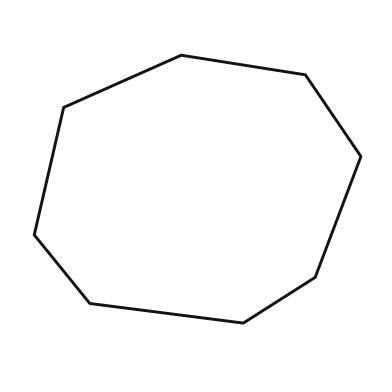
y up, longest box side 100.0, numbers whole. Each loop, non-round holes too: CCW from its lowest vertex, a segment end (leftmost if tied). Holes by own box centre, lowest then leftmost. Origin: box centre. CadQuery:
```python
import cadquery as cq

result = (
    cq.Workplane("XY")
    .moveTo(14.0, -41.0)
    .lineTo(36.0, -27.0)
    .lineTo(50.0, 10.0)
    .lineTo(33.0, 35.0)
    .lineTo(-5.0, 41.0)
    .lineTo(-41.0, 25.0)
    .lineTo(-50.0, -14.0)
    .lineTo(-33.0, -35.0)
    .close()
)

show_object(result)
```